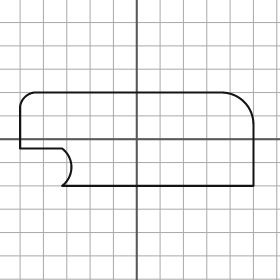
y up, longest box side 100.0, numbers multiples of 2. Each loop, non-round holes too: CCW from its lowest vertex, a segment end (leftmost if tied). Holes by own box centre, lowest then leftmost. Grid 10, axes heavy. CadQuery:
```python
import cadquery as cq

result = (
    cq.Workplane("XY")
    .moveTo(-32.0, -20.0)
    .lineTo(50.0, -20.0)
    .lineTo(50.0, 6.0)
    .threePointArc((46.0, 16.0), (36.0, 20.0))
    .lineTo(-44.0, 20.0)
    .threePointArc((-48.0, 18.0), (-50.0, 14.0))
    .lineTo(-50.0, -4.0)
    .lineTo(-32.0, -4.0)
    .threePointArc((-28.0, -12.0), (-32.0, -20.0))
    .close()
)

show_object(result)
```